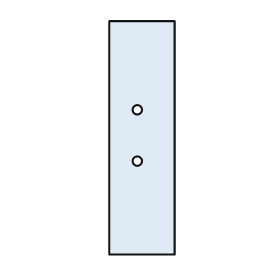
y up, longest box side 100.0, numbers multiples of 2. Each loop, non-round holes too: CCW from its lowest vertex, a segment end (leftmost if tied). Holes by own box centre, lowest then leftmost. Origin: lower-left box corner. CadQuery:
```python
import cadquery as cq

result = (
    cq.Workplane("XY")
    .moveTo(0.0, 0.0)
    .lineTo(28.0, 0.0)
    .lineTo(28.0, 100.0)
    .lineTo(0.0, 100.0)
    .close()
    .moveTo(12.0, 40.0)
    .circle(2.0)
    .moveTo(12.0, 62.0)
    .circle(2.0)
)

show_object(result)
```